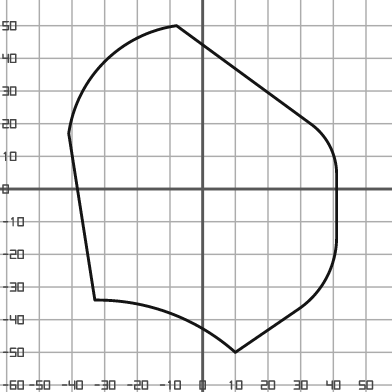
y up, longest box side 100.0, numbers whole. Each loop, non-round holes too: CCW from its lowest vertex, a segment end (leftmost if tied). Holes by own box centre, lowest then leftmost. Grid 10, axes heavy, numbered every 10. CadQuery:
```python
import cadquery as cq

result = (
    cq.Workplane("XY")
    .moveTo(10.0, -50.0)
    .lineTo(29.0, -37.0)
    .threePointArc((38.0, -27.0), (41.0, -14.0))
    .lineTo(41.0, 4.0)
    .threePointArc((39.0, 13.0), (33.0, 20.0))
    .lineTo(-8.0, 50.0)
    .threePointArc((-30.0, 39.0), (-41.0, 17.0))
    .lineTo(-33.0, -34.0)
    .threePointArc((-10.0, -38.0), (10.0, -50.0))
    .close()
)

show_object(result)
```